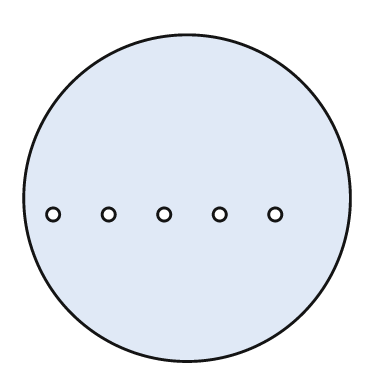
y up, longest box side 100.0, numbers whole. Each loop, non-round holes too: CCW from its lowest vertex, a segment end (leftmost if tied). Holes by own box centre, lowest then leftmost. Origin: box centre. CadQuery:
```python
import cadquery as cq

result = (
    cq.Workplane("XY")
    .moveTo(0.0, 0.0)
    .circle(50.0)
    .moveTo(-41.0, -5.0)
    .circle(2.0)
    .moveTo(-24.0, -5.0)
    .circle(2.0)
    .moveTo(-7.0, -5.0)
    .circle(2.0)
    .moveTo(10.0, -5.0)
    .circle(2.0)
    .moveTo(27.0, -5.0)
    .circle(2.0)
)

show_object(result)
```